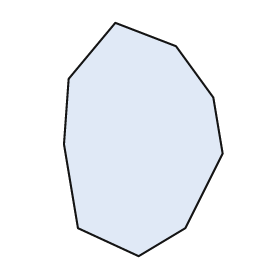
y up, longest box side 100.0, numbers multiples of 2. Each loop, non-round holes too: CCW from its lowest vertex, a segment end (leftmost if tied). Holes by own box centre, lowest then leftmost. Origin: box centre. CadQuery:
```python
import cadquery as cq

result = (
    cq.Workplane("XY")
    .moveTo(-2.0, -50.0)
    .lineTo(18.0, -38.0)
    .lineTo(34.0, -6.0)
    .lineTo(30.0, 18.0)
    .lineTo(14.0, 40.0)
    .lineTo(-12.0, 50.0)
    .lineTo(-32.0, 26.0)
    .lineTo(-34.0, -2.0)
    .lineTo(-28.0, -38.0)
    .close()
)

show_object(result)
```